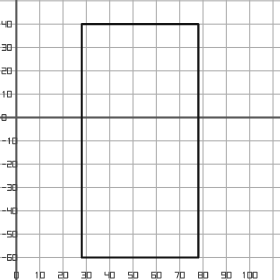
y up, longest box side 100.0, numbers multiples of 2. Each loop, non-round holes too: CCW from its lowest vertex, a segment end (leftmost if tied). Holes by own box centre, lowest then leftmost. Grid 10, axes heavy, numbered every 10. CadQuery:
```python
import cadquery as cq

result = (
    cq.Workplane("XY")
    .moveTo(28.0, -60.0)
    .lineTo(78.0, -60.0)
    .lineTo(78.0, 40.0)
    .lineTo(28.0, 40.0)
    .close()
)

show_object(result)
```